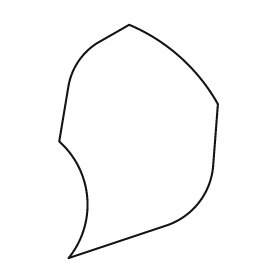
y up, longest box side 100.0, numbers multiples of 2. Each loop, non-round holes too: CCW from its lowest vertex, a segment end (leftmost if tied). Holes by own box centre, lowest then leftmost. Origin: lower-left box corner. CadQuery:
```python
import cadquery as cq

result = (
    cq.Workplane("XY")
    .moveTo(4.0, 0.0)
    .lineTo(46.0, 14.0)
    .threePointArc((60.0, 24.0), (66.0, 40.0))
    .lineTo(68.0, 66.0)
    .threePointArc((52.0, 86.0), (30.0, 100.0))
    .lineTo(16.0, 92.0)
    .threePointArc((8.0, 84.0), (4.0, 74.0))
    .lineTo(0.0, 50.0)
    .threePointArc((12.0, 26.0), (4.0, 0.0))
    .close()
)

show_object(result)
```